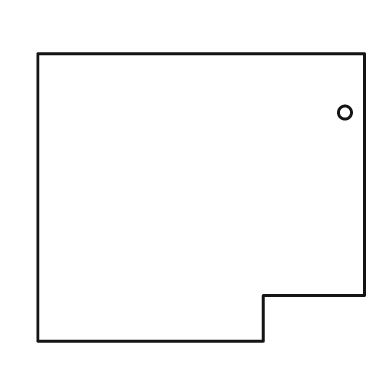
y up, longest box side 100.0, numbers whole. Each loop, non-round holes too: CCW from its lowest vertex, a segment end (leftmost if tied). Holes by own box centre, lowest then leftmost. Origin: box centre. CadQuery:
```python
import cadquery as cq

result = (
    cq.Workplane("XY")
    .moveTo(-50.0, -44.0)
    .lineTo(19.0, -44.0)
    .lineTo(19.0, -30.0)
    .lineTo(50.0, -30.0)
    .lineTo(50.0, 44.0)
    .lineTo(-50.0, 44.0)
    .close()
    .moveTo(44.0, 26.0)
    .circle(2.0)
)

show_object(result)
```